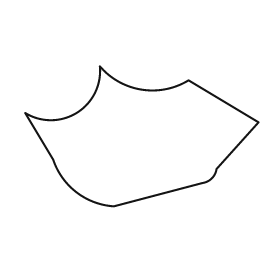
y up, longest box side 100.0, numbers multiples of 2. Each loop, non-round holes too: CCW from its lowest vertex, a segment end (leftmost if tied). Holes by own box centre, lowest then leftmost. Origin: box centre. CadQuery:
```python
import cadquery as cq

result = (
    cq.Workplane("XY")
    .moveTo(-12.0, -30.0)
    .lineTo(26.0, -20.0)
    .threePointArc((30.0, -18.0), (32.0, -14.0))
    .lineTo(50.0, 6.0)
    .lineTo(20.0, 24.0)
    .threePointArc((0.0, 20.0), (-18.0, 30.0))
    .threePointArc((-28.0, 10.0), (-50.0, 10.0))
    .lineTo(-38.0, -10.0)
    .threePointArc((-28.0, -24.0), (-12.0, -30.0))
    .close()
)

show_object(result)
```